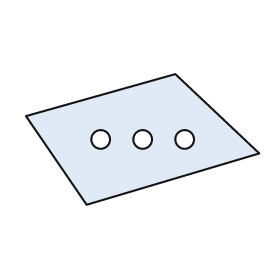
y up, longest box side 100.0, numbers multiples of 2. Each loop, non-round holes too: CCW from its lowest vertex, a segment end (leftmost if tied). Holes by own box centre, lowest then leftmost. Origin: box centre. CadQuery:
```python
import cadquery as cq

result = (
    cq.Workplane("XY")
    .moveTo(-24.0, -28.0)
    .lineTo(50.0, -6.0)
    .lineTo(14.0, 28.0)
    .lineTo(-50.0, 10.0)
    .close()
    .moveTo(-18.0, 0.0)
    .circle(4.0)
    .moveTo(0.0, 0.0)
    .circle(4.0)
    .moveTo(18.0, 0.0)
    .circle(4.0)
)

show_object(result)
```